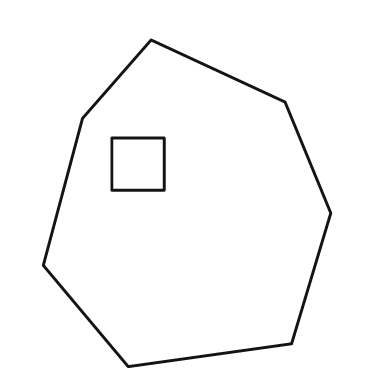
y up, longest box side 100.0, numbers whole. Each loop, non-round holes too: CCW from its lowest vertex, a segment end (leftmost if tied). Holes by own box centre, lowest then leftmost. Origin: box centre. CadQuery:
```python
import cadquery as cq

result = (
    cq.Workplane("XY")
    .moveTo(-18.0, -50.0)
    .lineTo(32.0, -43.0)
    .lineTo(44.0, -3.0)
    .lineTo(30.0, 31.0)
    .lineTo(-11.0, 50.0)
    .lineTo(-32.0, 26.0)
    .lineTo(-44.0, -19.0)
    .close()
    .moveTo(-23.0, 4.0)
    .lineTo(-7.0, 4.0)
    .lineTo(-7.0, 20.0)
    .lineTo(-23.0, 20.0)
    .close()
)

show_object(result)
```